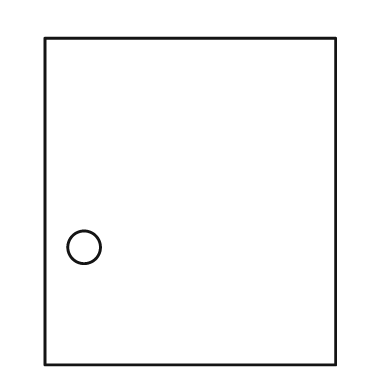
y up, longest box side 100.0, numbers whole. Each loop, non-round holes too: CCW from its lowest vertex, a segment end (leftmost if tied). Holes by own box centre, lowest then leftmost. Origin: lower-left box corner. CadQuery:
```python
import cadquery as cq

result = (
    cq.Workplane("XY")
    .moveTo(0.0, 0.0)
    .lineTo(89.0, 0.0)
    .lineTo(89.0, 100.0)
    .lineTo(0.0, 100.0)
    .close()
    .moveTo(12.0, 36.0)
    .circle(5.0)
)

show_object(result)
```